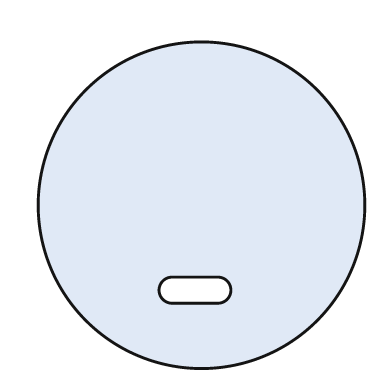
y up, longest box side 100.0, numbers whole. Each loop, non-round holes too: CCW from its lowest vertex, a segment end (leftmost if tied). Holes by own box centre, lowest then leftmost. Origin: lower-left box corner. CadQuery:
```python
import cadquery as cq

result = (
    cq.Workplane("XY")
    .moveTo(50.0, 50.0)
    .circle(50.0)
    .moveTo(41.0, 20.0)
    .lineTo(55.0, 20.0)
    .threePointArc((59.0, 24.0), (55.0, 28.0))
    .lineTo(41.0, 28.0)
    .threePointArc((37.0, 24.0), (41.0, 20.0))
    .close()
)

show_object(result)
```